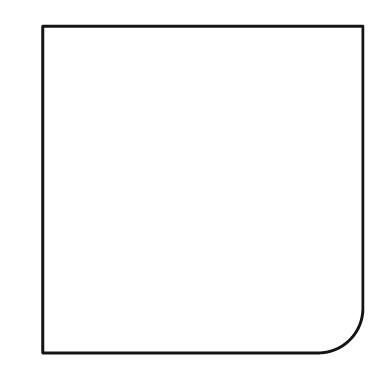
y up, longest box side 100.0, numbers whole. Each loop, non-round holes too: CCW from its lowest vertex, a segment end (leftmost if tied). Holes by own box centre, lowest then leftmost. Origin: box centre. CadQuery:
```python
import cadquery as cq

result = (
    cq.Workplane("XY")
    .moveTo(-49.0, -50.0)
    .lineTo(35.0, -50.0)
    .threePointArc((45.0, -46.0), (49.0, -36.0))
    .lineTo(49.0, 50.0)
    .lineTo(-49.0, 50.0)
    .close()
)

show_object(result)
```